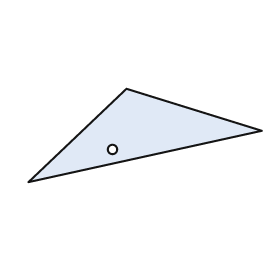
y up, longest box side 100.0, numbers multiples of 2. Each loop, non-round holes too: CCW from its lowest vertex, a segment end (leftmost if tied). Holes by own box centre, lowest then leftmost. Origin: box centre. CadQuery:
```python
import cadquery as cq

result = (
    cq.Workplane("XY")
    .moveTo(-50.0, -20.0)
    .lineTo(50.0, 2.0)
    .lineTo(-8.0, 20.0)
    .close()
    .moveTo(-14.0, -6.0)
    .circle(2.0)
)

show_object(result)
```